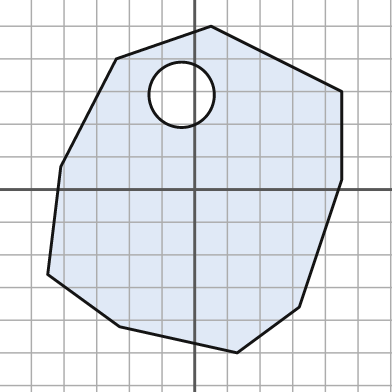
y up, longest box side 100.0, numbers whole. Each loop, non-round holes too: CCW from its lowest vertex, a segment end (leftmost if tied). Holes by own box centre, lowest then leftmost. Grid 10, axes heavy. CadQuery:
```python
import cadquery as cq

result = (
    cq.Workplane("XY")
    .moveTo(13.0, -50.0)
    .lineTo(32.0, -36.0)
    .lineTo(45.0, 3.0)
    .lineTo(45.0, 30.0)
    .lineTo(5.0, 50.0)
    .lineTo(-24.0, 40.0)
    .lineTo(-41.0, 7.0)
    .lineTo(-45.0, -26.0)
    .lineTo(-23.0, -42.0)
    .close()
    .moveTo(-4.0, 29.0)
    .circle(10.0)
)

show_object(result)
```